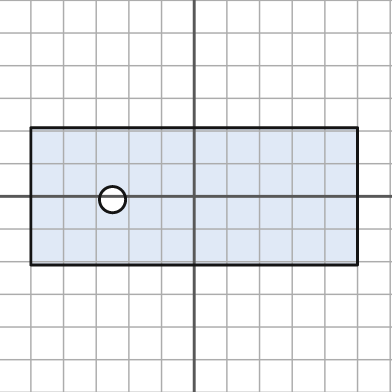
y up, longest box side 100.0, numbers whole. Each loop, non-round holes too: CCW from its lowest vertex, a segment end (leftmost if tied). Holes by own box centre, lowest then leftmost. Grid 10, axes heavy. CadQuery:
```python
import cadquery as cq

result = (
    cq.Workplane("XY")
    .moveTo(-50.0, -21.0)
    .lineTo(50.0, -21.0)
    .lineTo(50.0, 21.0)
    .lineTo(-50.0, 21.0)
    .close()
    .moveTo(-25.0, -1.0)
    .circle(4.0)
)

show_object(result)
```